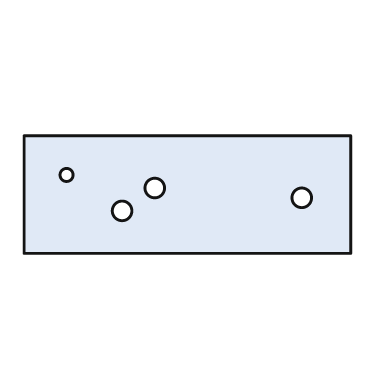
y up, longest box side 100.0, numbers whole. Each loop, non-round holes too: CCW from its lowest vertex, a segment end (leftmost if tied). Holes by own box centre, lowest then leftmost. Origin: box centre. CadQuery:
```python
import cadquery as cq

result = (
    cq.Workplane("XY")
    .moveTo(-50.0, -18.0)
    .lineTo(50.0, -18.0)
    .lineTo(50.0, 18.0)
    .lineTo(-50.0, 18.0)
    .close()
    .moveTo(-20.0, -5.0)
    .circle(3.0)
    .moveTo(35.0, -1.0)
    .circle(3.0)
    .moveTo(-10.0, 2.0)
    .circle(3.0)
    .moveTo(-37.0, 6.0)
    .circle(2.0)
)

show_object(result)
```